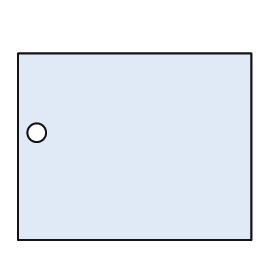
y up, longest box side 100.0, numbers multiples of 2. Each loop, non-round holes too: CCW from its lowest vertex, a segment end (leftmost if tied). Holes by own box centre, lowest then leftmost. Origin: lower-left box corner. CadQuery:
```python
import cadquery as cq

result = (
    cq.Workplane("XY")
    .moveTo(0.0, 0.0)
    .lineTo(100.0, 0.0)
    .lineTo(100.0, 80.0)
    .lineTo(0.0, 80.0)
    .close()
    .moveTo(8.0, 46.0)
    .circle(4.0)
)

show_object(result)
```